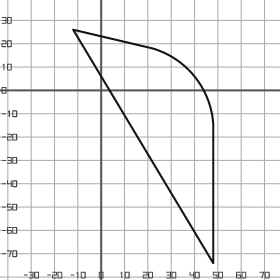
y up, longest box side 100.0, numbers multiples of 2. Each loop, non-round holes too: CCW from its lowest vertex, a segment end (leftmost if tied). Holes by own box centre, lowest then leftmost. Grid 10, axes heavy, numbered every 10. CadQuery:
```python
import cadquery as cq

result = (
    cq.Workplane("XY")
    .moveTo(48.0, -74.0)
    .lineTo(48.0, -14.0)
    .threePointArc((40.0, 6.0), (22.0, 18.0))
    .lineTo(-12.0, 26.0)
    .close()
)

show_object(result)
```